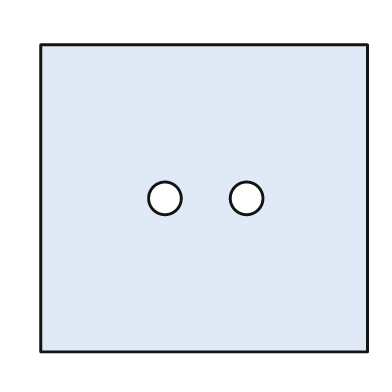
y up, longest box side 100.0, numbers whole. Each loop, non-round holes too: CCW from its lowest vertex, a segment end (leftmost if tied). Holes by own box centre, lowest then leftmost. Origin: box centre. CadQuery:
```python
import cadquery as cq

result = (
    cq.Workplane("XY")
    .moveTo(-50.0, -47.0)
    .lineTo(50.0, -47.0)
    .lineTo(50.0, 47.0)
    .lineTo(-50.0, 47.0)
    .close()
    .moveTo(-12.0, 0.0)
    .circle(5.0)
    .moveTo(13.0, 0.0)
    .circle(5.0)
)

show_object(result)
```